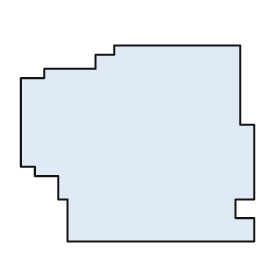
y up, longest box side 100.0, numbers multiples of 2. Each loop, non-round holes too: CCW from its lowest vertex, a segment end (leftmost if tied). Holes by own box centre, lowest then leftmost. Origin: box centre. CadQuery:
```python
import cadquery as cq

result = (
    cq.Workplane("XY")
    .moveTo(-30.0, -42.0)
    .lineTo(50.0, -42.0)
    .lineTo(50.0, -32.0)
    .lineTo(42.0, -32.0)
    .lineTo(42.0, -24.0)
    .lineTo(50.0, -24.0)
    .lineTo(50.0, 8.0)
    .lineTo(44.0, 8.0)
    .lineTo(44.0, 42.0)
    .lineTo(-10.0, 42.0)
    .lineTo(-10.0, 38.0)
    .lineTo(-18.0, 38.0)
    .lineTo(-18.0, 32.0)
    .lineTo(-40.0, 32.0)
    .lineTo(-40.0, 28.0)
    .lineTo(-50.0, 28.0)
    .lineTo(-50.0, -10.0)
    .lineTo(-44.0, -10.0)
    .lineTo(-44.0, -14.0)
    .lineTo(-34.0, -14.0)
    .lineTo(-34.0, -24.0)
    .lineTo(-30.0, -24.0)
    .close()
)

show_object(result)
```